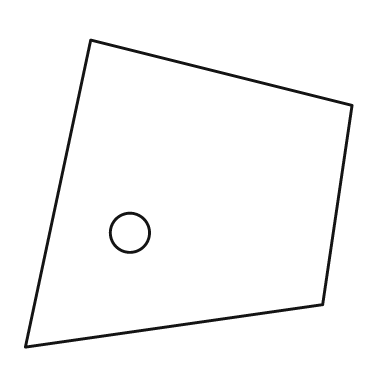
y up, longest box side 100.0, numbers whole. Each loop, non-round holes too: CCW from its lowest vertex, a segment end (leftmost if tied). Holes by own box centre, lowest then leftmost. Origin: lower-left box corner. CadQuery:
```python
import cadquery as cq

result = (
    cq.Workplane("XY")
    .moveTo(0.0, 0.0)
    .lineTo(91.0, 13.0)
    .lineTo(100.0, 74.0)
    .lineTo(20.0, 94.0)
    .close()
    .moveTo(32.0, 35.0)
    .circle(6.0)
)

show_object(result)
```